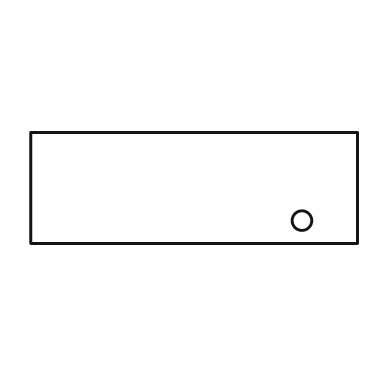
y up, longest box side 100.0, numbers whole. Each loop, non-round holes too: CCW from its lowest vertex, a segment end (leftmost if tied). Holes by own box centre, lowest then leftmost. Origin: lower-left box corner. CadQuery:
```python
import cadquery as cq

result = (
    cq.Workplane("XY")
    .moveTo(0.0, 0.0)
    .lineTo(100.0, 0.0)
    .lineTo(100.0, 34.0)
    .lineTo(0.0, 34.0)
    .close()
    .moveTo(83.0, 7.0)
    .circle(3.0)
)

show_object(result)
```